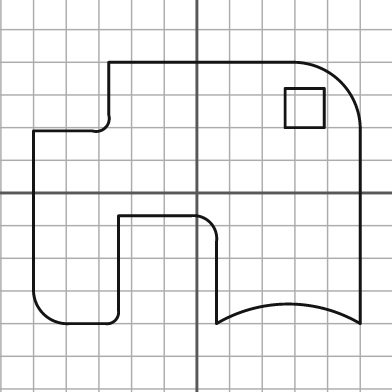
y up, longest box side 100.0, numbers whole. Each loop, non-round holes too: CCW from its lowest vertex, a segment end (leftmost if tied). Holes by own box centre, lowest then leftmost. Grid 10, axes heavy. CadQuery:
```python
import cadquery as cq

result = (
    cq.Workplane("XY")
    .moveTo(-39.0, -40.0)
    .lineTo(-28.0, -40.0)
    .threePointArc((-25.0, -39.0), (-24.0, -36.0))
    .lineTo(-24.0, -7.0)
    .lineTo(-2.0, -7.0)
    .threePointArc((4.0, -9.0), (6.0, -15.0))
    .lineTo(6.0, -40.0)
    .threePointArc((28.0, -34.0), (50.0, -40.0))
    .lineTo(50.0, 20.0)
    .threePointArc((44.0, 34.0), (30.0, 40.0))
    .lineTo(-27.0, 40.0)
    .lineTo(-27.0, 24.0)
    .threePointArc((-28.0, 20.0), (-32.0, 19.0))
    .lineTo(-50.0, 19.0)
    .lineTo(-50.0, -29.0)
    .threePointArc((-47.0, -37.0), (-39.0, -40.0))
    .close()
    .moveTo(27.0, 20.0)
    .lineTo(39.0, 20.0)
    .lineTo(39.0, 32.0)
    .lineTo(27.0, 32.0)
    .close()
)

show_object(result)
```